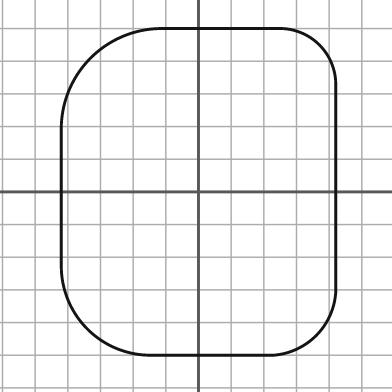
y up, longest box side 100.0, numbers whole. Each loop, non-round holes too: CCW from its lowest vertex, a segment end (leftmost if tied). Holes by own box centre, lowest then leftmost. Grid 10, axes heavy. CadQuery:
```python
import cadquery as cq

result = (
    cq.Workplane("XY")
    .moveTo(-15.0, -50.0)
    .lineTo(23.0, -50.0)
    .threePointArc((36.0, -44.0), (42.0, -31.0))
    .lineTo(42.0, 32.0)
    .threePointArc((37.0, 45.0), (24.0, 50.0))
    .lineTo(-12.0, 50.0)
    .threePointArc((-33.0, 41.0), (-42.0, 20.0))
    .lineTo(-42.0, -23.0)
    .threePointArc((-34.0, -42.0), (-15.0, -50.0))
    .close()
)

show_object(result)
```